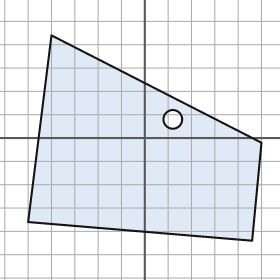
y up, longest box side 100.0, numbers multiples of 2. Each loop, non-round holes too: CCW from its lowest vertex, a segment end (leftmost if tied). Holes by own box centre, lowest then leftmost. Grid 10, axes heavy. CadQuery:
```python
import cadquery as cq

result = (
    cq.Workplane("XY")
    .moveTo(46.0, -44.0)
    .lineTo(50.0, -2.0)
    .lineTo(-40.0, 44.0)
    .lineTo(-50.0, -36.0)
    .close()
    .moveTo(12.0, 8.0)
    .circle(4.0)
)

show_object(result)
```